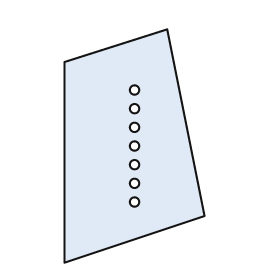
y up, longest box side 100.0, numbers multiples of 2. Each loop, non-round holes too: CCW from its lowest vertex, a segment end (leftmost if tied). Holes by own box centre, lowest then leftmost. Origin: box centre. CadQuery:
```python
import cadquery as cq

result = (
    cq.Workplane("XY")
    .moveTo(-30.0, -50.0)
    .lineTo(30.0, -30.0)
    .lineTo(14.0, 50.0)
    .lineTo(-30.0, 36.0)
    .close()
    .moveTo(0.0, -24.0)
    .circle(2.0)
    .moveTo(0.0, -16.0)
    .circle(2.0)
    .moveTo(0.0, -8.0)
    .circle(2.0)
    .moveTo(0.0, 0.0)
    .circle(2.0)
    .moveTo(0.0, 8.0)
    .circle(2.0)
    .moveTo(0.0, 16.0)
    .circle(2.0)
    .moveTo(0.0, 24.0)
    .circle(2.0)
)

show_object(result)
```